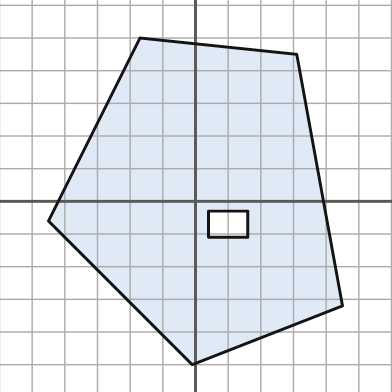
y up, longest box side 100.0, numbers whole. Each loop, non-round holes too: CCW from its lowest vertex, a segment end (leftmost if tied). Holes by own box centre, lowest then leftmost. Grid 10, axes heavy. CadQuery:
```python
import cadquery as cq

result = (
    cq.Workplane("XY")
    .moveTo(-1.0, -50.0)
    .lineTo(45.0, -32.0)
    .lineTo(31.0, 45.0)
    .lineTo(-17.0, 50.0)
    .lineTo(-45.0, -6.0)
    .close()
    .moveTo(4.0, -11.0)
    .lineTo(16.0, -11.0)
    .lineTo(16.0, -3.0)
    .lineTo(4.0, -3.0)
    .close()
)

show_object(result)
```